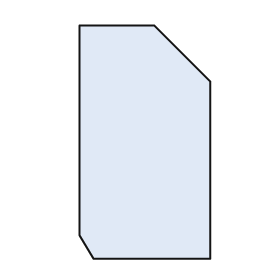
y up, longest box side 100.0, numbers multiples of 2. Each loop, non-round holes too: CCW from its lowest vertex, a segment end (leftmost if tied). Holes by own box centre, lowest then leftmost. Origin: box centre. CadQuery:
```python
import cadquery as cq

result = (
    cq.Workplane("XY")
    .moveTo(-22.0, -50.0)
    .lineTo(28.0, -50.0)
    .lineTo(28.0, 26.0)
    .lineTo(4.0, 50.0)
    .lineTo(-28.0, 50.0)
    .lineTo(-28.0, -40.0)
    .close()
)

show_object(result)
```